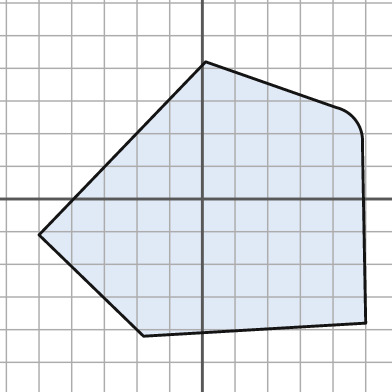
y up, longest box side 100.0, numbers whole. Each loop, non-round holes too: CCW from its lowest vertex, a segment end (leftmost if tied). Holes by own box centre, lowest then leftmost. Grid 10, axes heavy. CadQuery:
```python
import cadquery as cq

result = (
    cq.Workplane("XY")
    .moveTo(-18.0, -42.0)
    .lineTo(50.0, -38.0)
    .lineTo(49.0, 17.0)
    .threePointArc((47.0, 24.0), (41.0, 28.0))
    .lineTo(1.0, 42.0)
    .lineTo(-50.0, -11.0)
    .close()
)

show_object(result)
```